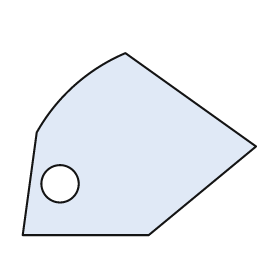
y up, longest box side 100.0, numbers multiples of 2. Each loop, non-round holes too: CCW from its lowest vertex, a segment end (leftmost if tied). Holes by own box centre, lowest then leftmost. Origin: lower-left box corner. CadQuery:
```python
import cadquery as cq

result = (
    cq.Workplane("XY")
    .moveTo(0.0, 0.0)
    .lineTo(54.0, 0.0)
    .lineTo(100.0, 38.0)
    .lineTo(44.0, 78.0)
    .threePointArc((22.0, 64.0), (6.0, 44.0))
    .close()
    .moveTo(16.0, 22.0)
    .circle(8.0)
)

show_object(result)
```